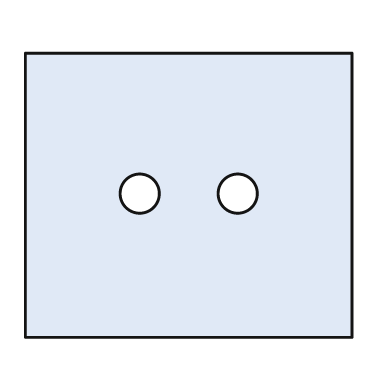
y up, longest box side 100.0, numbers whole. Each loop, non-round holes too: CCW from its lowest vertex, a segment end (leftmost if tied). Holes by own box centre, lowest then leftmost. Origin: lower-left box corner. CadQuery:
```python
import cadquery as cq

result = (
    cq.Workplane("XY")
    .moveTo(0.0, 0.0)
    .lineTo(100.0, 0.0)
    .lineTo(100.0, 87.0)
    .lineTo(0.0, 87.0)
    .close()
    .moveTo(35.0, 44.0)
    .circle(6.0)
    .moveTo(65.0, 44.0)
    .circle(6.0)
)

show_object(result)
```